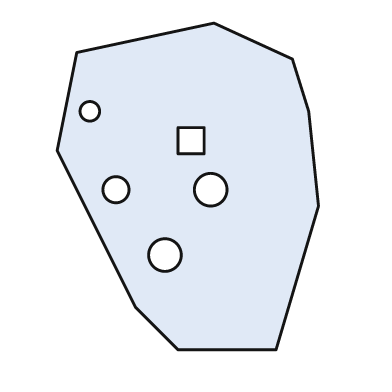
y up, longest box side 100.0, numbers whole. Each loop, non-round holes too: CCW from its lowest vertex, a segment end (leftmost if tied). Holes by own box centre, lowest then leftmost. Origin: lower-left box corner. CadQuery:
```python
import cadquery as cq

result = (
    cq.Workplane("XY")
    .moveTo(37.0, 0.0)
    .lineTo(67.0, 0.0)
    .lineTo(80.0, 44.0)
    .lineTo(77.0, 73.0)
    .lineTo(72.0, 89.0)
    .lineTo(48.0, 100.0)
    .lineTo(6.0, 91.0)
    .lineTo(0.0, 61.0)
    .lineTo(24.0, 13.0)
    .close()
    .moveTo(33.0, 29.0)
    .circle(5.0)
    .moveTo(18.0, 49.0)
    .circle(4.0)
    .moveTo(47.0, 49.0)
    .circle(5.0)
    .moveTo(37.0, 60.0)
    .lineTo(45.0, 60.0)
    .lineTo(45.0, 68.0)
    .lineTo(37.0, 68.0)
    .close()
    .moveTo(10.0, 73.0)
    .circle(3.0)
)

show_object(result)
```